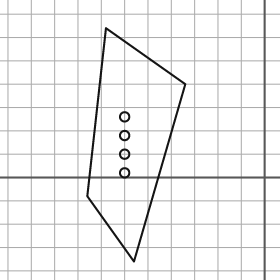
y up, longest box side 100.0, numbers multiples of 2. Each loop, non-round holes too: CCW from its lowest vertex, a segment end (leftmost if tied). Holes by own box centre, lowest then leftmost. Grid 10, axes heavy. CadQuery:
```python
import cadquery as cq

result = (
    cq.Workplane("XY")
    .moveTo(-56.0, -36.0)
    .lineTo(-34.0, 40.0)
    .lineTo(-68.0, 64.0)
    .lineTo(-76.0, -8.0)
    .close()
    .moveTo(-60.0, 2.0)
    .circle(2.0)
    .moveTo(-60.0, 10.0)
    .circle(2.0)
    .moveTo(-60.0, 18.0)
    .circle(2.0)
    .moveTo(-60.0, 26.0)
    .circle(2.0)
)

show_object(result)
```